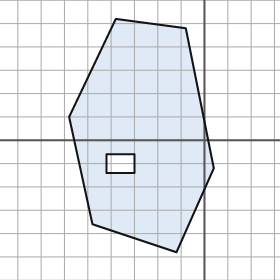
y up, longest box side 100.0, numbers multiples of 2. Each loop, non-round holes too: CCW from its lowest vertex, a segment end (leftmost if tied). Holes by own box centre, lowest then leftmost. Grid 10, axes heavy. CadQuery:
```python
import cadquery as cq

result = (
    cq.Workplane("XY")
    .moveTo(-12.0, -48.0)
    .lineTo(4.0, -12.0)
    .lineTo(-8.0, 48.0)
    .lineTo(-38.0, 52.0)
    .lineTo(-58.0, 10.0)
    .lineTo(-48.0, -36.0)
    .close()
    .moveTo(-42.0, -14.0)
    .lineTo(-30.0, -14.0)
    .lineTo(-30.0, -6.0)
    .lineTo(-42.0, -6.0)
    .close()
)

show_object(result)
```